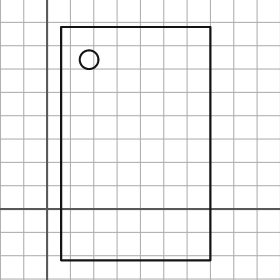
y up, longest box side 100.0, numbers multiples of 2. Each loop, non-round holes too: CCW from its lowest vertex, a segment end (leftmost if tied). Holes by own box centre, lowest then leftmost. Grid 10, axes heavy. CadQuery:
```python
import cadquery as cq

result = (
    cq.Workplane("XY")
    .moveTo(6.0, -22.0)
    .lineTo(70.0, -22.0)
    .lineTo(70.0, 78.0)
    .lineTo(6.0, 78.0)
    .close()
    .moveTo(18.0, 64.0)
    .circle(4.0)
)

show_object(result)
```